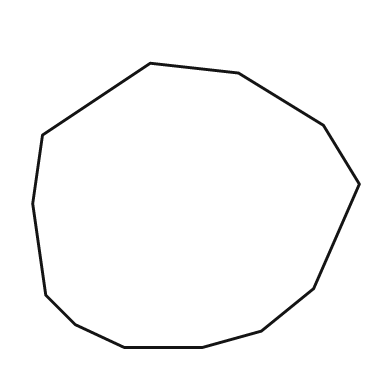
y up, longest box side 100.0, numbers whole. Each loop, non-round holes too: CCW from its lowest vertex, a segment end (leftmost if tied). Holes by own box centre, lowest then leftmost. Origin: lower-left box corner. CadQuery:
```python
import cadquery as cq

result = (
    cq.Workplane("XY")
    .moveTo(28.0, 0.0)
    .lineTo(52.0, 0.0)
    .lineTo(70.0, 5.0)
    .lineTo(86.0, 18.0)
    .lineTo(100.0, 50.0)
    .lineTo(89.0, 68.0)
    .lineTo(63.0, 84.0)
    .lineTo(36.0, 87.0)
    .lineTo(3.0, 65.0)
    .lineTo(0.0, 44.0)
    .lineTo(4.0, 16.0)
    .lineTo(13.0, 7.0)
    .close()
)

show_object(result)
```